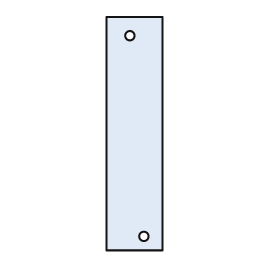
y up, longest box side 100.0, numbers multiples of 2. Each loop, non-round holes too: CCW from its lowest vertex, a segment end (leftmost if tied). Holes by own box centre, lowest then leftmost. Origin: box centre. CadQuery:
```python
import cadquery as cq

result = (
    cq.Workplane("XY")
    .moveTo(-12.0, -50.0)
    .lineTo(12.0, -50.0)
    .lineTo(12.0, 50.0)
    .lineTo(-12.0, 50.0)
    .close()
    .moveTo(4.0, -44.0)
    .circle(2.0)
    .moveTo(-2.0, 42.0)
    .circle(2.0)
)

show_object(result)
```